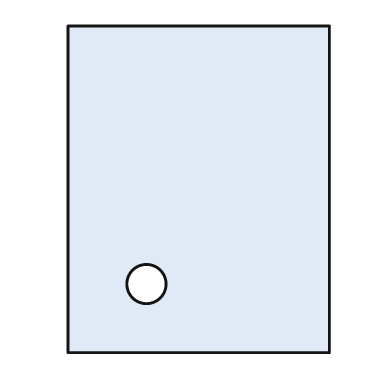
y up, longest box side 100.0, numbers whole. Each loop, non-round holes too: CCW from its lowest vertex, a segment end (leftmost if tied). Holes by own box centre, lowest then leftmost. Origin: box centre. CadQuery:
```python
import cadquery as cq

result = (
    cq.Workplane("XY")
    .moveTo(-40.0, -50.0)
    .lineTo(40.0, -50.0)
    .lineTo(40.0, 50.0)
    .lineTo(-40.0, 50.0)
    .close()
    .moveTo(-16.0, -29.0)
    .circle(6.0)
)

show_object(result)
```